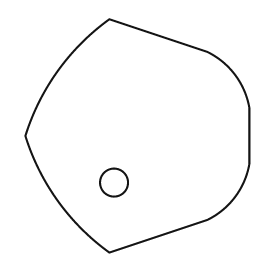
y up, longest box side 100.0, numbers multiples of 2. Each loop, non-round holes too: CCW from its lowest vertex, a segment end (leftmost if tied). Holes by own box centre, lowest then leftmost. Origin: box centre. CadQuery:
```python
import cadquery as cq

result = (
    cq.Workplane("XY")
    .moveTo(-12.0, -50.0)
    .lineTo(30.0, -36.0)
    .threePointArc((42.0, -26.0), (48.0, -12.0))
    .lineTo(48.0, 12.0)
    .threePointArc((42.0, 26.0), (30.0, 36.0))
    .lineTo(-12.0, 50.0)
    .threePointArc((-34.0, 28.0), (-48.0, 0.0))
    .threePointArc((-34.0, -28.0), (-12.0, -50.0))
    .close()
    .moveTo(-10.0, -20.0)
    .circle(6.0)
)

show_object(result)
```